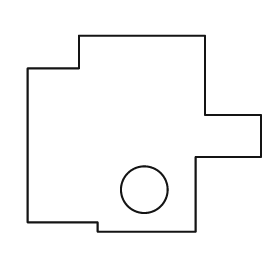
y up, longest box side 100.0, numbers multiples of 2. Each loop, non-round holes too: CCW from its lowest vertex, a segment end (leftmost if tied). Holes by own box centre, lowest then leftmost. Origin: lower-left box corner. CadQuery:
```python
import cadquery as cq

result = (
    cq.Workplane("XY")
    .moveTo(30.0, 0.0)
    .lineTo(72.0, 0.0)
    .lineTo(72.0, 32.0)
    .lineTo(100.0, 32.0)
    .lineTo(100.0, 50.0)
    .lineTo(76.0, 50.0)
    .lineTo(76.0, 84.0)
    .lineTo(22.0, 84.0)
    .lineTo(22.0, 70.0)
    .lineTo(0.0, 70.0)
    .lineTo(0.0, 4.0)
    .lineTo(30.0, 4.0)
    .close()
    .moveTo(50.0, 18.0)
    .circle(10.0)
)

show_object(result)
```